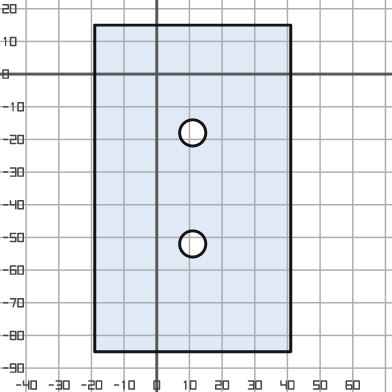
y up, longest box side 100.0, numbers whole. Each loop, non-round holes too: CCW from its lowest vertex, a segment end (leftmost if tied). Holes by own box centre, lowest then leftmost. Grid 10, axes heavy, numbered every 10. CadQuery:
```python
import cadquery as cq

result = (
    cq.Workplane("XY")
    .moveTo(-19.0, -85.0)
    .lineTo(41.0, -85.0)
    .lineTo(41.0, 15.0)
    .lineTo(-19.0, 15.0)
    .close()
    .moveTo(11.0, -52.0)
    .circle(4.0)
    .moveTo(11.0, -18.0)
    .circle(4.0)
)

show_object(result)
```